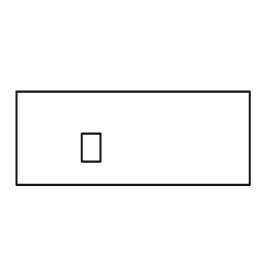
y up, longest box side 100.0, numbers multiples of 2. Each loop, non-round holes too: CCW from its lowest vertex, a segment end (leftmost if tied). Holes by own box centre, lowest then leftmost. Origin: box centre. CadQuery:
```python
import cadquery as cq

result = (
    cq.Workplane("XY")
    .moveTo(-50.0, -20.0)
    .lineTo(50.0, -20.0)
    .lineTo(50.0, 20.0)
    .lineTo(-50.0, 20.0)
    .close()
    .moveTo(-22.0, -10.0)
    .lineTo(-14.0, -10.0)
    .lineTo(-14.0, 2.0)
    .lineTo(-22.0, 2.0)
    .close()
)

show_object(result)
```